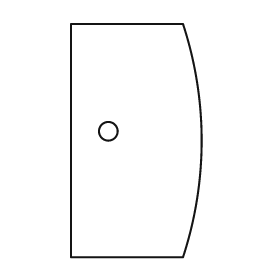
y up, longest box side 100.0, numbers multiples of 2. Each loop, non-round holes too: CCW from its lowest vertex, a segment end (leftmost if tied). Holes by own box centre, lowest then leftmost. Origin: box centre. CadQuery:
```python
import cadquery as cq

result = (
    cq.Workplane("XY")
    .moveTo(-28.0, -50.0)
    .lineTo(20.0, -50.0)
    .threePointArc((28.0, 0.0), (20.0, 50.0))
    .lineTo(-28.0, 50.0)
    .close()
    .moveTo(-12.0, 4.0)
    .circle(4.0)
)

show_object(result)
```